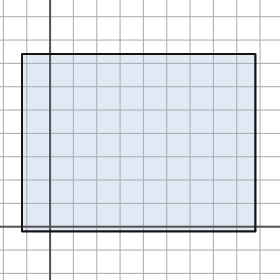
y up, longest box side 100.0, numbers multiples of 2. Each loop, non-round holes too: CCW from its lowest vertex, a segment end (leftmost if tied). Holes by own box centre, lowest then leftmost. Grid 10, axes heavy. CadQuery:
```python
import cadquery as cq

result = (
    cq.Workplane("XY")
    .moveTo(-12.0, -2.0)
    .lineTo(88.0, -2.0)
    .lineTo(88.0, 74.0)
    .lineTo(-12.0, 74.0)
    .close()
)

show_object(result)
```